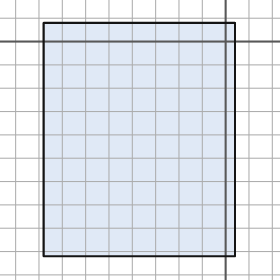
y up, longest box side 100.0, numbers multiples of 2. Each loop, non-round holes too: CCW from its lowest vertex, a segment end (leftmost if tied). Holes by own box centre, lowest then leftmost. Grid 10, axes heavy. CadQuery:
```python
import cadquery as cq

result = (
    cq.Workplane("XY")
    .moveTo(-78.0, -92.0)
    .lineTo(4.0, -92.0)
    .lineTo(4.0, 8.0)
    .lineTo(-78.0, 8.0)
    .close()
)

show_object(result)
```